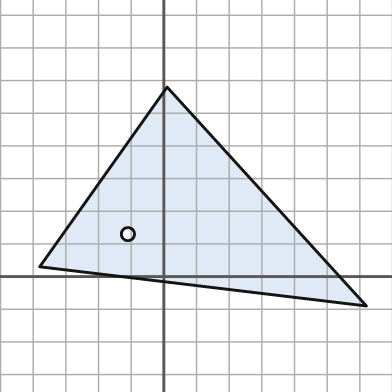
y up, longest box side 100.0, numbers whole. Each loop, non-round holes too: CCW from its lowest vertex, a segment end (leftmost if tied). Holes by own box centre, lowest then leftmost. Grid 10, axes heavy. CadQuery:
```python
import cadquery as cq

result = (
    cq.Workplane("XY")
    .moveTo(62.0, -9.0)
    .lineTo(1.0, 58.0)
    .lineTo(-38.0, 3.0)
    .close()
    .moveTo(-11.0, 13.0)
    .circle(2.0)
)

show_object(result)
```